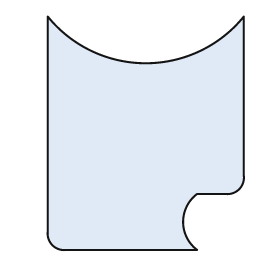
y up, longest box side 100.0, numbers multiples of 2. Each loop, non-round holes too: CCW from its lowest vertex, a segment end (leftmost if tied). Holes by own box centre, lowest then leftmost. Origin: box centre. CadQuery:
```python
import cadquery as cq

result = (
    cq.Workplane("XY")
    .moveTo(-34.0, -50.0)
    .lineTo(22.0, -50.0)
    .threePointArc((16.0, -38.0), (22.0, -26.0))
    .lineTo(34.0, -26.0)
    .threePointArc((40.0, -24.0), (42.0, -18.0))
    .lineTo(42.0, 50.0)
    .threePointArc((0.0, 30.0), (-42.0, 50.0))
    .lineTo(-42.0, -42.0)
    .threePointArc((-40.0, -48.0), (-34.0, -50.0))
    .close()
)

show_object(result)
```